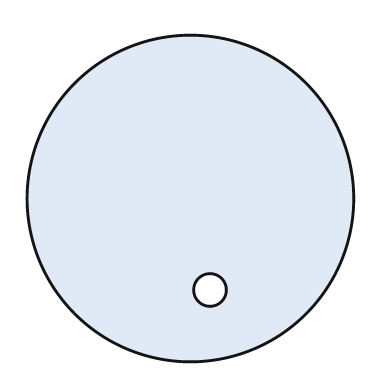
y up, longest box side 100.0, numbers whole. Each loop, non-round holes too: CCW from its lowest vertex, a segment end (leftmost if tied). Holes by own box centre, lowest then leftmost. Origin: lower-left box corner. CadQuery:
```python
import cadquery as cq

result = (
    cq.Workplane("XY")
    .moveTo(50.0, 50.0)
    .circle(50.0)
    .moveTo(56.0, 22.0)
    .circle(5.0)
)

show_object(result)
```